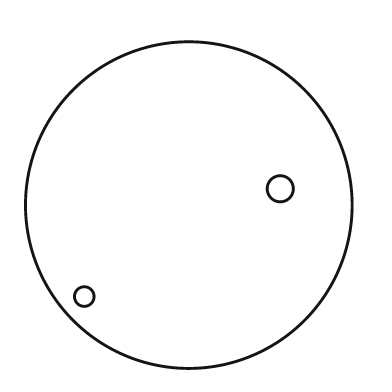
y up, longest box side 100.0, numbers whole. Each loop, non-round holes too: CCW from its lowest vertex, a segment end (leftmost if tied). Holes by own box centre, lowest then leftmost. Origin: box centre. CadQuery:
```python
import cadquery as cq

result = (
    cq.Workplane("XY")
    .moveTo(0.0, 0.0)
    .circle(50.0)
    .moveTo(-32.0, -28.0)
    .circle(3.0)
    .moveTo(28.0, 5.0)
    .circle(4.0)
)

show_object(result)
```